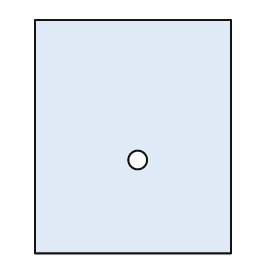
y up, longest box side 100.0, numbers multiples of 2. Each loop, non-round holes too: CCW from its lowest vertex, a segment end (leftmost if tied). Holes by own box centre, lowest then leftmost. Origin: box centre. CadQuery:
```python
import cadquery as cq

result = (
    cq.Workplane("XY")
    .moveTo(-42.0, -50.0)
    .lineTo(42.0, -50.0)
    .lineTo(42.0, 50.0)
    .lineTo(-42.0, 50.0)
    .close()
    .moveTo(2.0, -10.0)
    .circle(4.0)
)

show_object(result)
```